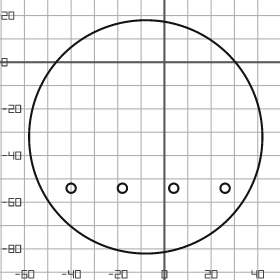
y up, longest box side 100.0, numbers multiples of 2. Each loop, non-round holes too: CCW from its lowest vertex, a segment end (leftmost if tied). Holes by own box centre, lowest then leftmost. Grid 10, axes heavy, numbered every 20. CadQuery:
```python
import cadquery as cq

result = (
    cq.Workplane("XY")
    .moveTo(-8.0, -32.0)
    .circle(50.0)
    .moveTo(-40.0, -54.0)
    .circle(2.0)
    .moveTo(-18.0, -54.0)
    .circle(2.0)
    .moveTo(4.0, -54.0)
    .circle(2.0)
    .moveTo(26.0, -54.0)
    .circle(2.0)
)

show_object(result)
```